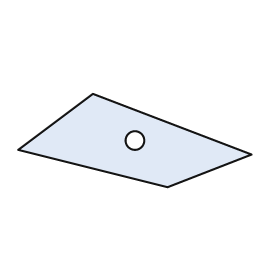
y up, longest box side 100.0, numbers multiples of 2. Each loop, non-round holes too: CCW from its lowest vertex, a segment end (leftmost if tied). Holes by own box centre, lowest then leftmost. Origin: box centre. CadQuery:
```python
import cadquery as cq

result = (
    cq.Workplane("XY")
    .moveTo(14.0, -20.0)
    .lineTo(50.0, -6.0)
    .lineTo(-18.0, 20.0)
    .lineTo(-50.0, -4.0)
    .close()
    .moveTo(0.0, 0.0)
    .circle(4.0)
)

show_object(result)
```